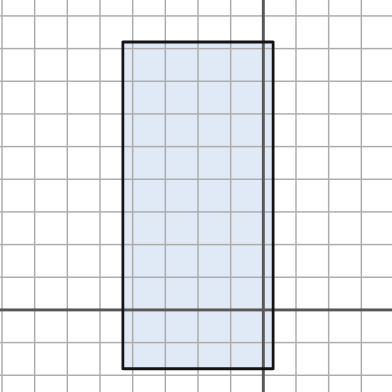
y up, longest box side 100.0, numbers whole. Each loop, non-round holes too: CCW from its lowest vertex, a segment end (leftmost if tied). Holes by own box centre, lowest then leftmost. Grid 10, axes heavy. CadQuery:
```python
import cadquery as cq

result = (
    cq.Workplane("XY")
    .moveTo(-43.0, -18.0)
    .lineTo(3.0, -18.0)
    .lineTo(3.0, 82.0)
    .lineTo(-43.0, 82.0)
    .close()
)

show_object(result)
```